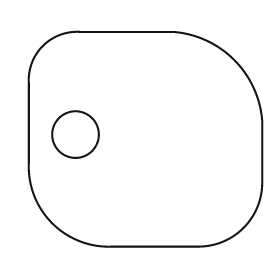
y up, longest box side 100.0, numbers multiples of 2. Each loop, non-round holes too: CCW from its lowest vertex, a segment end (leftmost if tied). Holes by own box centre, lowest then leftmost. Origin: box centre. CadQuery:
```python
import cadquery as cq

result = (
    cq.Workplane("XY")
    .moveTo(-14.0, -46.0)
    .lineTo(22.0, -46.0)
    .threePointArc((42.0, -38.0), (50.0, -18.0))
    .lineTo(50.0, 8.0)
    .threePointArc((38.0, 34.0), (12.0, 46.0))
    .lineTo(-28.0, 46.0)
    .threePointArc((-44.0, 40.0), (-50.0, 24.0))
    .lineTo(-50.0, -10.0)
    .threePointArc((-40.0, -36.0), (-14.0, -46.0))
    .close()
    .moveTo(-30.0, 2.0)
    .circle(10.0)
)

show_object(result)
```